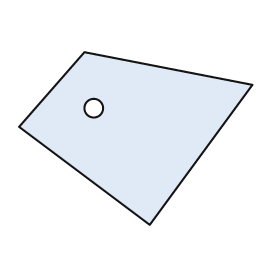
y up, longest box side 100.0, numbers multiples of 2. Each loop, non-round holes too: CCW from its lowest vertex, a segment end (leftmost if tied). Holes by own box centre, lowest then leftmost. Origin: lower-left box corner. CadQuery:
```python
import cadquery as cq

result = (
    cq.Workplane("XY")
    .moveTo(56.0, 0.0)
    .lineTo(100.0, 60.0)
    .lineTo(28.0, 74.0)
    .lineTo(0.0, 42.0)
    .close()
    .moveTo(32.0, 50.0)
    .circle(4.0)
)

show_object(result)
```